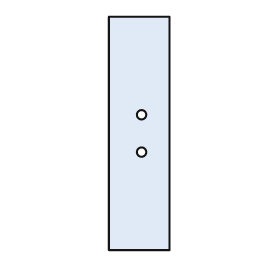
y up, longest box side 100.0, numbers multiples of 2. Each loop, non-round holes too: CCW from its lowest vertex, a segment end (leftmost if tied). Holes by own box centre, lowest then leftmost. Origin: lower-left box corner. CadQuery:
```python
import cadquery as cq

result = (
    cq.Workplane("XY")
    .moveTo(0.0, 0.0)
    .lineTo(26.0, 0.0)
    .lineTo(26.0, 100.0)
    .lineTo(0.0, 100.0)
    .close()
    .moveTo(14.0, 42.0)
    .circle(2.0)
    .moveTo(14.0, 58.0)
    .circle(2.0)
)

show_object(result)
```